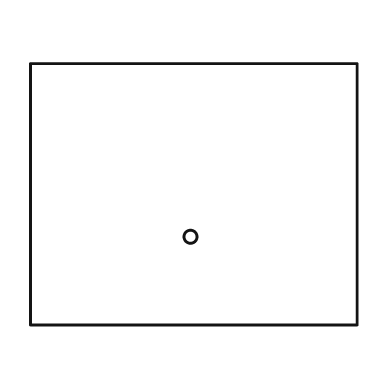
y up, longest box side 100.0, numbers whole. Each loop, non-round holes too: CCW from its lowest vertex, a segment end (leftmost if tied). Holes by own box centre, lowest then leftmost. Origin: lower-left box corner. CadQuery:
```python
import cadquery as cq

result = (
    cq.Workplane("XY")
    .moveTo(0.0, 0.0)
    .lineTo(100.0, 0.0)
    .lineTo(100.0, 80.0)
    .lineTo(0.0, 80.0)
    .close()
    .moveTo(49.0, 27.0)
    .circle(2.0)
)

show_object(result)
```